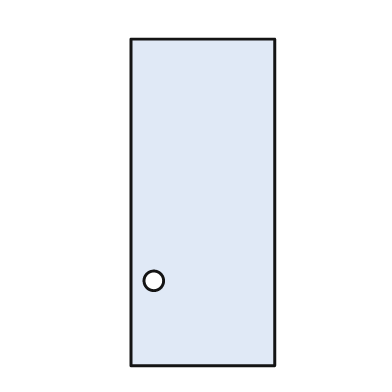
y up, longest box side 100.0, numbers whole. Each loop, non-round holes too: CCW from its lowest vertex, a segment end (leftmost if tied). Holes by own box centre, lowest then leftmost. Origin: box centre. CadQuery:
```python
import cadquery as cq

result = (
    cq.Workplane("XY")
    .moveTo(-22.0, -50.0)
    .lineTo(22.0, -50.0)
    .lineTo(22.0, 50.0)
    .lineTo(-22.0, 50.0)
    .close()
    .moveTo(-15.0, -24.0)
    .circle(3.0)
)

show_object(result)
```